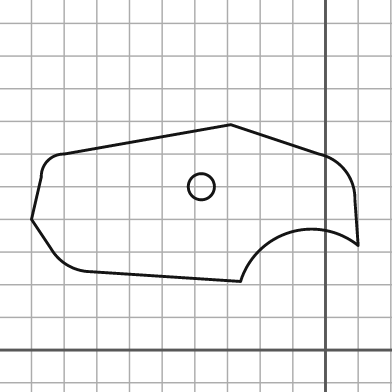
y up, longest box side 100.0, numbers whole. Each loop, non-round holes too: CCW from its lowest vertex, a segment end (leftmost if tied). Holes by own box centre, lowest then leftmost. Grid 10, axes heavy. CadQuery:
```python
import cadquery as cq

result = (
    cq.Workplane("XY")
    .moveTo(-26.0, 21.0)
    .threePointArc((-11.0, 36.0), (10.0, 32.0))
    .lineTo(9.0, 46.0)
    .threePointArc((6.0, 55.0), (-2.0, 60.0))
    .lineTo(-29.0, 69.0)
    .lineTo(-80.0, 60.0)
    .threePointArc((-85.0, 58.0), (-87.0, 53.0))
    .lineTo(-90.0, 40.0)
    .lineTo(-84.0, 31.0)
    .threePointArc((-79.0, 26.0), (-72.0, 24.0))
    .close()
    .moveTo(-38.0, 50.0)
    .circle(4.0)
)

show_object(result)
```